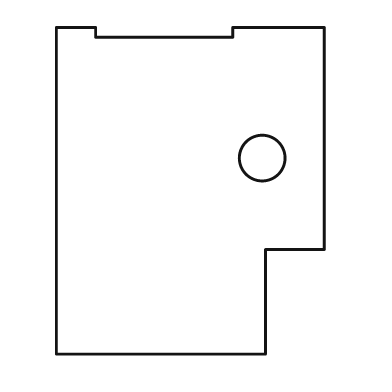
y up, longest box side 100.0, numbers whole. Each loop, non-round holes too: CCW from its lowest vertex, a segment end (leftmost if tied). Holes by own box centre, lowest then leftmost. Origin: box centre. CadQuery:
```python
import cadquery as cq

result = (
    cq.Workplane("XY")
    .moveTo(-41.0, -50.0)
    .lineTo(23.0, -50.0)
    .lineTo(23.0, -18.0)
    .lineTo(41.0, -18.0)
    .lineTo(41.0, 50.0)
    .lineTo(13.0, 50.0)
    .lineTo(13.0, 47.0)
    .lineTo(-29.0, 47.0)
    .lineTo(-29.0, 50.0)
    .lineTo(-41.0, 50.0)
    .close()
    .moveTo(22.0, 10.0)
    .circle(7.0)
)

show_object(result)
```